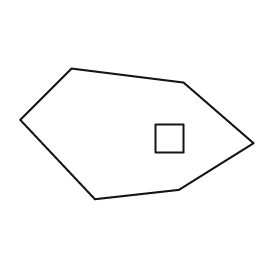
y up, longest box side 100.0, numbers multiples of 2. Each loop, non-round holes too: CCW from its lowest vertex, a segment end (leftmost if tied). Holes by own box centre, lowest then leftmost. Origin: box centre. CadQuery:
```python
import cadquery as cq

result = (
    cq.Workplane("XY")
    .moveTo(-18.0, -28.0)
    .lineTo(18.0, -24.0)
    .lineTo(50.0, -4.0)
    .lineTo(20.0, 22.0)
    .lineTo(-28.0, 28.0)
    .lineTo(-50.0, 6.0)
    .close()
    .moveTo(8.0, -8.0)
    .lineTo(20.0, -8.0)
    .lineTo(20.0, 4.0)
    .lineTo(8.0, 4.0)
    .close()
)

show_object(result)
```